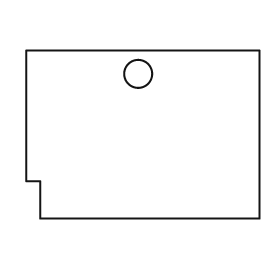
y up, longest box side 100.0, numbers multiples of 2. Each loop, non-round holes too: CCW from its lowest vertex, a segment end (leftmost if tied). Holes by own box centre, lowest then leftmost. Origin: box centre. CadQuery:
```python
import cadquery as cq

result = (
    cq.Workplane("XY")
    .moveTo(-44.0, -36.0)
    .lineTo(50.0, -36.0)
    .lineTo(50.0, 36.0)
    .lineTo(-50.0, 36.0)
    .lineTo(-50.0, -20.0)
    .lineTo(-44.0, -20.0)
    .close()
    .moveTo(-2.0, 26.0)
    .circle(6.0)
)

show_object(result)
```